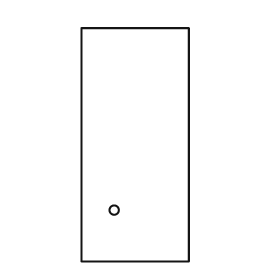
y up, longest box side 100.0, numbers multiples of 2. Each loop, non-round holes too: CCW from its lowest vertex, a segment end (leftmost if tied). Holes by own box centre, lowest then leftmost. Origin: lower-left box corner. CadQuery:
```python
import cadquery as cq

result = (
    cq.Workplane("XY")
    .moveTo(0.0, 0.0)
    .lineTo(46.0, 0.0)
    .lineTo(46.0, 100.0)
    .lineTo(0.0, 100.0)
    .close()
    .moveTo(14.0, 22.0)
    .circle(2.0)
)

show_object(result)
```